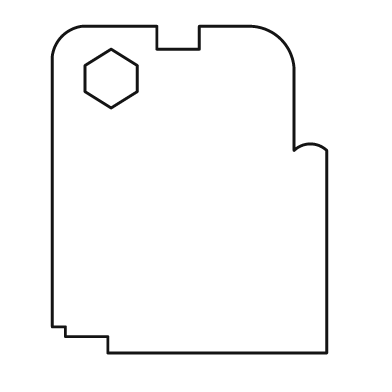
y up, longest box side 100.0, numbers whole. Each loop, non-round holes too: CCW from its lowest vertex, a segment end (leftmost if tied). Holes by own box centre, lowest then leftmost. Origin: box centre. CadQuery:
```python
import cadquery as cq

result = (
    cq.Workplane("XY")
    .moveTo(-25.0, -50.0)
    .lineTo(42.0, -50.0)
    .lineTo(42.0, 12.0)
    .threePointArc((37.0, 14.0), (32.0, 12.0))
    .lineTo(32.0, 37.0)
    .threePointArc((28.0, 46.0), (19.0, 50.0))
    .lineTo(3.0, 50.0)
    .lineTo(3.0, 43.0)
    .lineTo(-10.0, 43.0)
    .lineTo(-10.0, 50.0)
    .lineTo(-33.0, 50.0)
    .threePointArc((-39.0, 47.0), (-42.0, 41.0))
    .lineTo(-42.0, -42.0)
    .lineTo(-38.0, -42.0)
    .lineTo(-38.0, -45.0)
    .lineTo(-25.0, -45.0)
    .close()
    .moveTo(-24.0, 25.0)
    .lineTo(-16.0, 30.0)
    .lineTo(-16.0, 38.0)
    .lineTo(-24.0, 43.0)
    .lineTo(-32.0, 38.0)
    .lineTo(-32.0, 30.0)
    .close()
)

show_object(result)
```